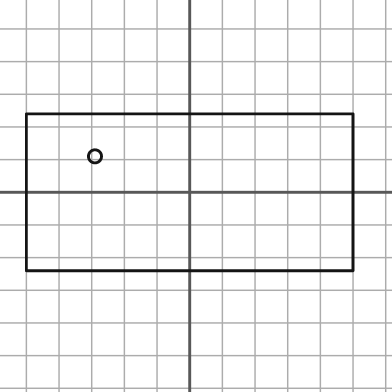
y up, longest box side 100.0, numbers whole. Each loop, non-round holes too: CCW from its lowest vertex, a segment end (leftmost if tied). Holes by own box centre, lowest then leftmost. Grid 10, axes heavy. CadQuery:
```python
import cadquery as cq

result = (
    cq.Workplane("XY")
    .moveTo(-50.0, -24.0)
    .lineTo(50.0, -24.0)
    .lineTo(50.0, 24.0)
    .lineTo(-50.0, 24.0)
    .close()
    .moveTo(-29.0, 11.0)
    .circle(2.0)
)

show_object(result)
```